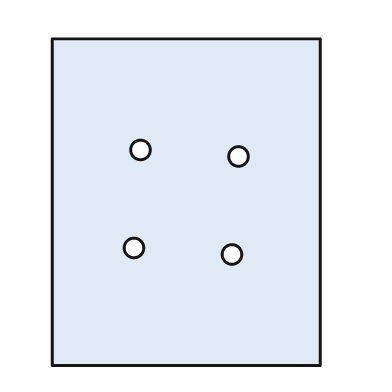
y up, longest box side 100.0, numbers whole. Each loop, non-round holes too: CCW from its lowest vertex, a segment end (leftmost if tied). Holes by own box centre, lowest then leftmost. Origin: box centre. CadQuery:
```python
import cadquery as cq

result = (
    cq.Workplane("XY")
    .moveTo(-41.0, -50.0)
    .lineTo(41.0, -50.0)
    .lineTo(41.0, 50.0)
    .lineTo(-41.0, 50.0)
    .close()
    .moveTo(14.0, -16.0)
    .circle(3.0)
    .moveTo(-16.0, -14.0)
    .circle(3.0)
    .moveTo(16.0, 14.0)
    .circle(3.0)
    .moveTo(-14.0, 16.0)
    .circle(3.0)
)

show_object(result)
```